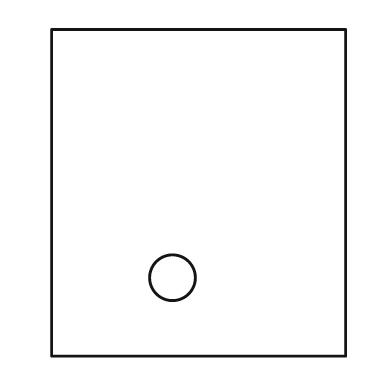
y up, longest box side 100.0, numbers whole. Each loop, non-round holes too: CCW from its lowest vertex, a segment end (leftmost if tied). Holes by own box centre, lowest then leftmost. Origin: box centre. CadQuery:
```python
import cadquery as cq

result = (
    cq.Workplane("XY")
    .moveTo(-45.0, -50.0)
    .lineTo(45.0, -50.0)
    .lineTo(45.0, 50.0)
    .lineTo(-45.0, 50.0)
    .close()
    .moveTo(-8.0, -26.0)
    .circle(7.0)
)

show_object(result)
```